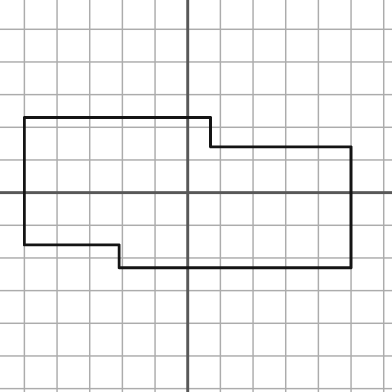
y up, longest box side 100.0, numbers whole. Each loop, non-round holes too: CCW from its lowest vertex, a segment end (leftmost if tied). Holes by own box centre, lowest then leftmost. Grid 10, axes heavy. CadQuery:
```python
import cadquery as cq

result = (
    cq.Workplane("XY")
    .moveTo(-21.0, -23.0)
    .lineTo(50.0, -23.0)
    .lineTo(50.0, 14.0)
    .lineTo(7.0, 14.0)
    .lineTo(7.0, 23.0)
    .lineTo(-50.0, 23.0)
    .lineTo(-50.0, -16.0)
    .lineTo(-21.0, -16.0)
    .close()
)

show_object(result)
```